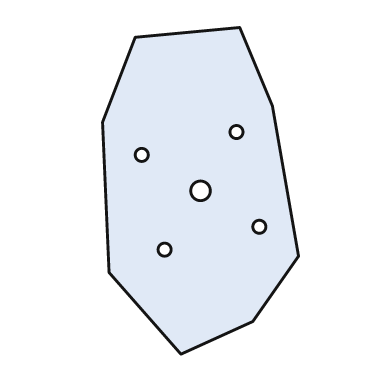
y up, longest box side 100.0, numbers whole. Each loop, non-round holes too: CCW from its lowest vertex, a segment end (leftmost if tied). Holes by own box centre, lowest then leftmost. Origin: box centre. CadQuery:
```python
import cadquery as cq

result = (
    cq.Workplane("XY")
    .moveTo(-6.0, -50.0)
    .lineTo(16.0, -40.0)
    .lineTo(30.0, -20.0)
    .lineTo(22.0, 26.0)
    .lineTo(12.0, 50.0)
    .lineTo(-20.0, 47.0)
    .lineTo(-30.0, 21.0)
    .lineTo(-28.0, -25.0)
    .close()
    .moveTo(-11.0, -18.0)
    .circle(2.0)
    .moveTo(18.0, -11.0)
    .circle(2.0)
    .moveTo(0.0, 0.0)
    .circle(3.0)
    .moveTo(-18.0, 11.0)
    .circle(2.0)
    .moveTo(11.0, 18.0)
    .circle(2.0)
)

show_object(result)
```